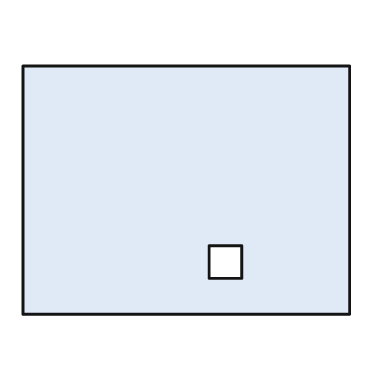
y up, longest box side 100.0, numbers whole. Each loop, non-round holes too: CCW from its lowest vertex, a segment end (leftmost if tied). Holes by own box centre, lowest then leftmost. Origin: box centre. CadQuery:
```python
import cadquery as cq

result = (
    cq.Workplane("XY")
    .moveTo(-50.0, -38.0)
    .lineTo(50.0, -38.0)
    .lineTo(50.0, 38.0)
    .lineTo(-50.0, 38.0)
    .close()
    .moveTo(7.0, -27.0)
    .lineTo(17.0, -27.0)
    .lineTo(17.0, -17.0)
    .lineTo(7.0, -17.0)
    .close()
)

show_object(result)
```